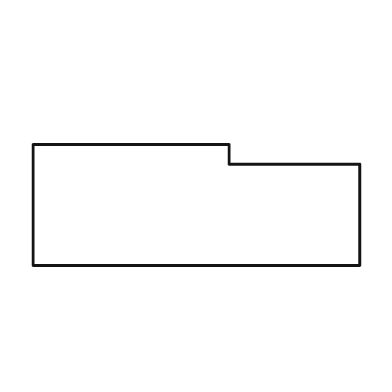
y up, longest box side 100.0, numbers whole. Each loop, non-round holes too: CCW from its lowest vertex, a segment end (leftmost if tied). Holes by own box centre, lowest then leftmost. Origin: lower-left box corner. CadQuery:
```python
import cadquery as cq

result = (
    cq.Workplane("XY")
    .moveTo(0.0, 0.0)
    .lineTo(100.0, 0.0)
    .lineTo(100.0, 31.0)
    .lineTo(60.0, 31.0)
    .lineTo(60.0, 37.0)
    .lineTo(0.0, 37.0)
    .close()
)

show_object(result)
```